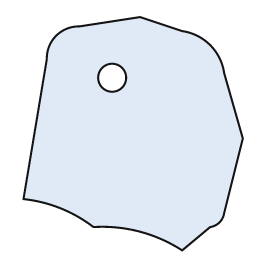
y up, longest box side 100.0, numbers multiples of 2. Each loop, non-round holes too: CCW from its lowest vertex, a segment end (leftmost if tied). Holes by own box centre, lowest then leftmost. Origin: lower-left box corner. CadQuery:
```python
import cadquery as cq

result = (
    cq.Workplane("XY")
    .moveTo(68.0, 0.0)
    .lineTo(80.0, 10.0)
    .threePointArc((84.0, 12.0), (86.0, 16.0))
    .lineTo(94.0, 48.0)
    .lineTo(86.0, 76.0)
    .threePointArc((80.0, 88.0), (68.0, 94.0))
    .lineTo(50.0, 100.0)
    .lineTo(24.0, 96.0)
    .threePointArc((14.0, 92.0), (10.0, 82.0))
    .lineTo(0.0, 22.0)
    .threePointArc((16.0, 18.0), (30.0, 10.0))
    .threePointArc((50.0, 8.0), (68.0, 0.0))
    .close()
    .moveTo(38.0, 74.0)
    .circle(6.0)
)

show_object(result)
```